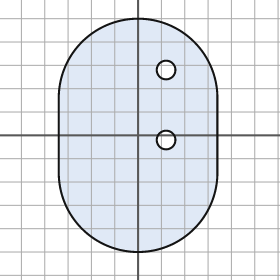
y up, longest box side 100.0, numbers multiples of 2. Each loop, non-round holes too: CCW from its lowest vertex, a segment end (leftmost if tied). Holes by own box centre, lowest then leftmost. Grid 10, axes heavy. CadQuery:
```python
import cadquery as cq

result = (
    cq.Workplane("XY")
    .moveTo(-34.0, -16.0)
    .threePointArc((0.0, -50.0), (34.0, -16.0))
    .lineTo(34.0, 16.0)
    .threePointArc((0.0, 50.0), (-34.0, 16.0))
    .close()
    .moveTo(12.0, -2.0)
    .circle(4.0)
    .moveTo(12.0, 28.0)
    .circle(4.0)
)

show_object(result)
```